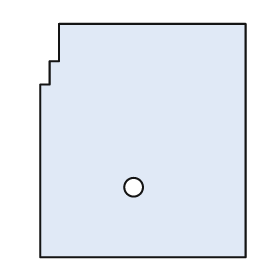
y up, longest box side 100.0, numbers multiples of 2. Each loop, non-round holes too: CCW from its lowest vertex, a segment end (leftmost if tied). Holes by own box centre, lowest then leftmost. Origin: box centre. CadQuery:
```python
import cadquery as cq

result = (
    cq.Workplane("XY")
    .moveTo(-44.0, -50.0)
    .lineTo(44.0, -50.0)
    .lineTo(44.0, 50.0)
    .lineTo(-36.0, 50.0)
    .lineTo(-36.0, 34.0)
    .lineTo(-40.0, 34.0)
    .lineTo(-40.0, 24.0)
    .lineTo(-44.0, 24.0)
    .close()
    .moveTo(-4.0, -20.0)
    .circle(4.0)
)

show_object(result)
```